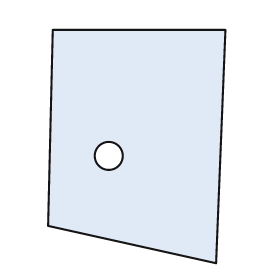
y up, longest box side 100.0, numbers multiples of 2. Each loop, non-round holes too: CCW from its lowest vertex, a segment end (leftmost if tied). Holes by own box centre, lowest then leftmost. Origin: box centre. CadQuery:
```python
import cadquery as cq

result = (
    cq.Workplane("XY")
    .moveTo(34.0, -50.0)
    .lineTo(38.0, 50.0)
    .lineTo(-36.0, 50.0)
    .lineTo(-38.0, -34.0)
    .close()
    .moveTo(-12.0, -4.0)
    .circle(6.0)
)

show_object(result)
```